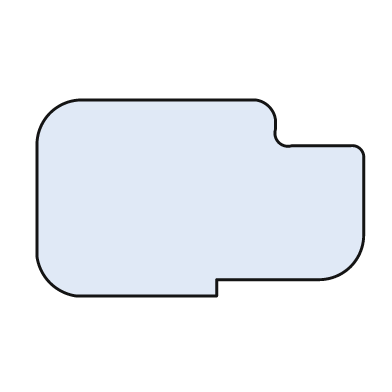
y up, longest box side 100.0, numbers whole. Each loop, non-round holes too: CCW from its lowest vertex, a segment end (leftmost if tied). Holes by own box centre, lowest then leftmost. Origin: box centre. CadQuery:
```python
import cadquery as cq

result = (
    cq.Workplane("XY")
    .moveTo(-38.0, -30.0)
    .lineTo(5.0, -30.0)
    .lineTo(5.0, -25.0)
    .lineTo(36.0, -25.0)
    .threePointArc((46.0, -21.0), (50.0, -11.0))
    .lineTo(50.0, 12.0)
    .threePointArc((49.0, 15.0), (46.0, 16.0))
    .lineTo(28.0, 16.0)
    .threePointArc((24.0, 17.0), (23.0, 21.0))
    .lineTo(23.0, 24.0)
    .threePointArc((21.0, 28.0), (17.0, 30.0))
    .lineTo(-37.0, 30.0)
    .threePointArc((-46.0, 26.0), (-50.0, 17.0))
    .lineTo(-50.0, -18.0)
    .threePointArc((-46.0, -26.0), (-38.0, -30.0))
    .close()
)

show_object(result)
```